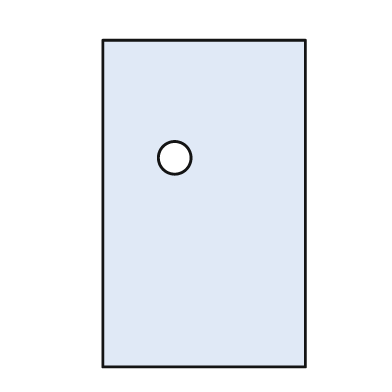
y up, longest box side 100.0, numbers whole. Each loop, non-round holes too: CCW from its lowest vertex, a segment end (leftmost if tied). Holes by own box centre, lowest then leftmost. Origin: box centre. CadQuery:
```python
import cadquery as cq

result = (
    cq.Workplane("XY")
    .moveTo(-31.0, -50.0)
    .lineTo(31.0, -50.0)
    .lineTo(31.0, 50.0)
    .lineTo(-31.0, 50.0)
    .close()
    .moveTo(-9.0, 14.0)
    .circle(5.0)
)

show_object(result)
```